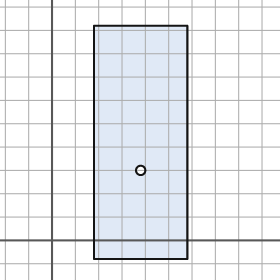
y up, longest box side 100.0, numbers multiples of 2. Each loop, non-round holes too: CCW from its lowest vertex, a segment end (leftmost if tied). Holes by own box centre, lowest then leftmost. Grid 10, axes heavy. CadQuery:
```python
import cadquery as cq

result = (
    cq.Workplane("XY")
    .moveTo(18.0, -8.0)
    .lineTo(58.0, -8.0)
    .lineTo(58.0, 92.0)
    .lineTo(18.0, 92.0)
    .close()
    .moveTo(38.0, 30.0)
    .circle(2.0)
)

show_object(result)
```